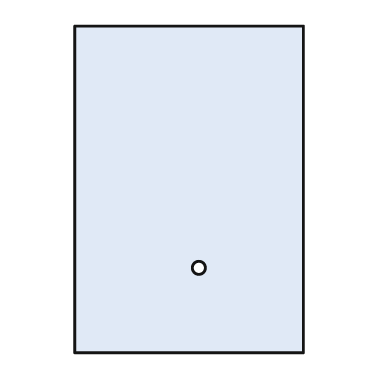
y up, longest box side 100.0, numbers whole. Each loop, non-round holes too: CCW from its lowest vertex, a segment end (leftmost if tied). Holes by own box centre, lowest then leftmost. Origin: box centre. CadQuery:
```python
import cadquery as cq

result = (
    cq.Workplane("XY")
    .moveTo(-35.0, -50.0)
    .lineTo(35.0, -50.0)
    .lineTo(35.0, 50.0)
    .lineTo(-35.0, 50.0)
    .close()
    .moveTo(3.0, -24.0)
    .circle(2.0)
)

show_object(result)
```